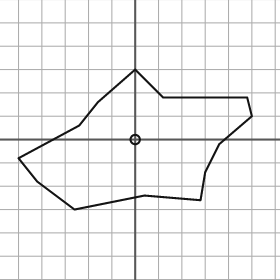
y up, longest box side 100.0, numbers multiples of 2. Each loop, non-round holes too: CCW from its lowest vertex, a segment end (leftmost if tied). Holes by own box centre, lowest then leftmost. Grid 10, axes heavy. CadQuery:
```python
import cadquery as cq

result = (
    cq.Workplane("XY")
    .moveTo(-26.0, -30.0)
    .lineTo(4.0, -24.0)
    .lineTo(28.0, -26.0)
    .lineTo(30.0, -14.0)
    .lineTo(36.0, -2.0)
    .lineTo(50.0, 10.0)
    .lineTo(48.0, 18.0)
    .lineTo(12.0, 18.0)
    .lineTo(0.0, 30.0)
    .lineTo(-16.0, 16.0)
    .lineTo(-24.0, 6.0)
    .lineTo(-50.0, -8.0)
    .lineTo(-42.0, -18.0)
    .close()
    .moveTo(0.0, 0.0)
    .circle(2.0)
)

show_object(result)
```